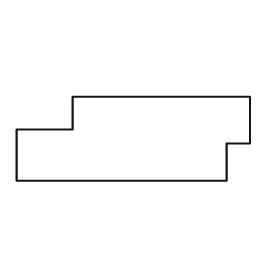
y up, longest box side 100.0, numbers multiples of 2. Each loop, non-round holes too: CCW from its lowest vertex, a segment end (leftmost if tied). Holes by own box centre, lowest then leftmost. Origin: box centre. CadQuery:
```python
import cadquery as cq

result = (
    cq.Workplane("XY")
    .moveTo(-50.0, -18.0)
    .lineTo(40.0, -18.0)
    .lineTo(40.0, -2.0)
    .lineTo(50.0, -2.0)
    .lineTo(50.0, 18.0)
    .lineTo(-26.0, 18.0)
    .lineTo(-26.0, 4.0)
    .lineTo(-50.0, 4.0)
    .close()
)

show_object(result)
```